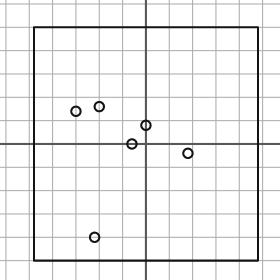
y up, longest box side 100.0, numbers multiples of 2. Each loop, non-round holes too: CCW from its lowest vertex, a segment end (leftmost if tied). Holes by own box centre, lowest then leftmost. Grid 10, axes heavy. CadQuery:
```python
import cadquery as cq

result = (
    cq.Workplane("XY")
    .moveTo(-48.0, -50.0)
    .lineTo(48.0, -50.0)
    .lineTo(48.0, 50.0)
    .lineTo(-48.0, 50.0)
    .close()
    .moveTo(-22.0, -40.0)
    .circle(2.0)
    .moveTo(18.0, -4.0)
    .circle(2.0)
    .moveTo(-6.0, 0.0)
    .circle(2.0)
    .moveTo(0.0, 8.0)
    .circle(2.0)
    .moveTo(-30.0, 14.0)
    .circle(2.0)
    .moveTo(-20.0, 16.0)
    .circle(2.0)
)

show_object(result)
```